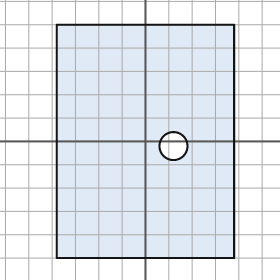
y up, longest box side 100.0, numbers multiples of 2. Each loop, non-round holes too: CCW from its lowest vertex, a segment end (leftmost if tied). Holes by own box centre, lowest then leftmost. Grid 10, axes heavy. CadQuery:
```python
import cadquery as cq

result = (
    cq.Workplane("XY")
    .moveTo(-38.0, -50.0)
    .lineTo(38.0, -50.0)
    .lineTo(38.0, 50.0)
    .lineTo(-38.0, 50.0)
    .close()
    .moveTo(12.0, -2.0)
    .circle(6.0)
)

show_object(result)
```